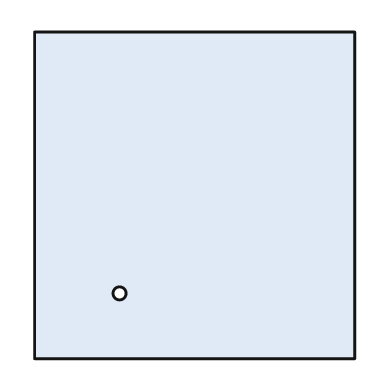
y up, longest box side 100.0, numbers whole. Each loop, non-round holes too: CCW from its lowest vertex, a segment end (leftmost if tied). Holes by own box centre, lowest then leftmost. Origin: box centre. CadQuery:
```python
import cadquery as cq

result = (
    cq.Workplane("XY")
    .moveTo(-49.0, -50.0)
    .lineTo(49.0, -50.0)
    .lineTo(49.0, 50.0)
    .lineTo(-49.0, 50.0)
    .close()
    .moveTo(-23.0, -30.0)
    .circle(2.0)
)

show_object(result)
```